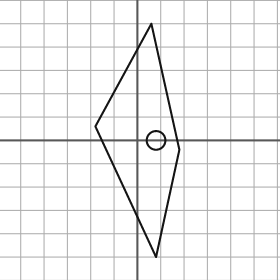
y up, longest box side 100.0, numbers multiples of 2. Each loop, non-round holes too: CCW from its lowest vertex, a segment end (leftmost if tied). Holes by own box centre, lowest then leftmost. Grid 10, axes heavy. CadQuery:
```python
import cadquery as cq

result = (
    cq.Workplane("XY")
    .moveTo(8.0, -50.0)
    .lineTo(18.0, -4.0)
    .lineTo(6.0, 50.0)
    .lineTo(-18.0, 6.0)
    .close()
    .moveTo(8.0, 0.0)
    .circle(4.0)
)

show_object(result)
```